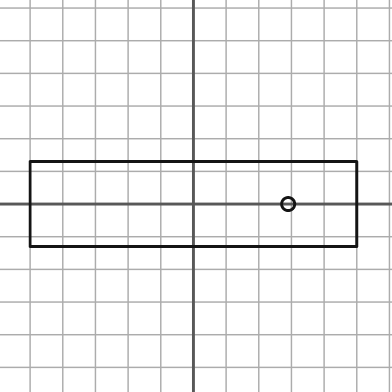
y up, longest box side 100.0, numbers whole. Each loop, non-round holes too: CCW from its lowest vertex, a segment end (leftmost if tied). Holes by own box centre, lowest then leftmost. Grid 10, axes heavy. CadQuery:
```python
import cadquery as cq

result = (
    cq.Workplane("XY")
    .moveTo(-50.0, -13.0)
    .lineTo(50.0, -13.0)
    .lineTo(50.0, 13.0)
    .lineTo(-50.0, 13.0)
    .close()
    .moveTo(29.0, 0.0)
    .circle(2.0)
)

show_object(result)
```